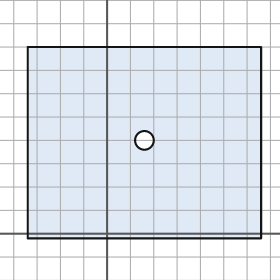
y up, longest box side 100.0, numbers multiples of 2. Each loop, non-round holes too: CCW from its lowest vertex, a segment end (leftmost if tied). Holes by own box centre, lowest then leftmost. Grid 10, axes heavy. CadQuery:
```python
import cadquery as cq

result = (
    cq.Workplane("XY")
    .moveTo(-34.0, -2.0)
    .lineTo(66.0, -2.0)
    .lineTo(66.0, 80.0)
    .lineTo(-34.0, 80.0)
    .close()
    .moveTo(16.0, 40.0)
    .circle(4.0)
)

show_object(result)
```